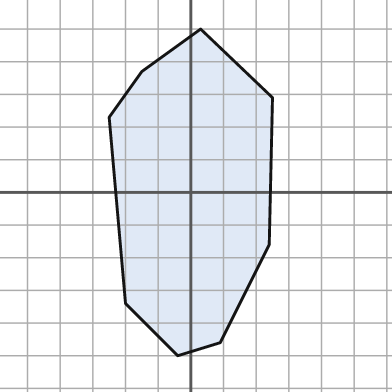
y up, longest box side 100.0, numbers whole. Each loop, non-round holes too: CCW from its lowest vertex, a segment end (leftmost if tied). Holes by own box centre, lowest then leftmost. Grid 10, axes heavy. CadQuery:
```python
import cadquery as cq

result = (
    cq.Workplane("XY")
    .moveTo(-4.0, -50.0)
    .lineTo(9.0, -46.0)
    .lineTo(24.0, -16.0)
    .lineTo(25.0, 29.0)
    .lineTo(3.0, 50.0)
    .lineTo(-15.0, 37.0)
    .lineTo(-25.0, 23.0)
    .lineTo(-20.0, -34.0)
    .close()
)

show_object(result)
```